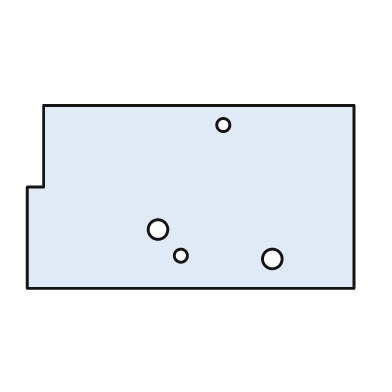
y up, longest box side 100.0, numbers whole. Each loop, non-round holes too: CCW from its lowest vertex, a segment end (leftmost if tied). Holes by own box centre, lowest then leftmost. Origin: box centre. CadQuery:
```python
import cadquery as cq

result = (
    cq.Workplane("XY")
    .moveTo(-50.0, -28.0)
    .lineTo(50.0, -28.0)
    .lineTo(50.0, 28.0)
    .lineTo(-45.0, 28.0)
    .lineTo(-45.0, 3.0)
    .lineTo(-50.0, 3.0)
    .close()
    .moveTo(25.0, -19.0)
    .circle(3.0)
    .moveTo(-3.0, -18.0)
    .circle(2.0)
    .moveTo(-10.0, -10.0)
    .circle(3.0)
    .moveTo(10.0, 22.0)
    .circle(2.0)
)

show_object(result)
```